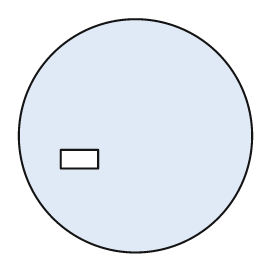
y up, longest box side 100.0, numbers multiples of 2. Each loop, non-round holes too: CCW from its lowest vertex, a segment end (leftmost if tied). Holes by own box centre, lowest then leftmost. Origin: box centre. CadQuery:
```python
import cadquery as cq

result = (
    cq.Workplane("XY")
    .moveTo(0.0, 0.0)
    .circle(50.0)
    .moveTo(-32.0, -14.0)
    .lineTo(-16.0, -14.0)
    .lineTo(-16.0, -6.0)
    .lineTo(-32.0, -6.0)
    .close()
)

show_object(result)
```